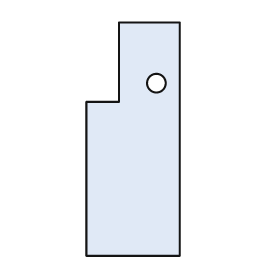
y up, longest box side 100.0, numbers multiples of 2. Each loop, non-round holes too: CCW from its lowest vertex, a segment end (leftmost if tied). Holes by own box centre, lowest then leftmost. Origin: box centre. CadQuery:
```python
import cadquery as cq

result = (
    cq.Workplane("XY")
    .moveTo(-20.0, -50.0)
    .lineTo(20.0, -50.0)
    .lineTo(20.0, 50.0)
    .lineTo(-6.0, 50.0)
    .lineTo(-6.0, 16.0)
    .lineTo(-20.0, 16.0)
    .close()
    .moveTo(10.0, 24.0)
    .circle(4.0)
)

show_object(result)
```